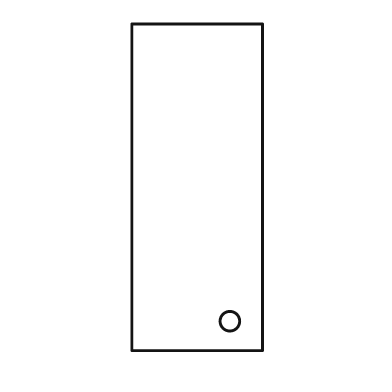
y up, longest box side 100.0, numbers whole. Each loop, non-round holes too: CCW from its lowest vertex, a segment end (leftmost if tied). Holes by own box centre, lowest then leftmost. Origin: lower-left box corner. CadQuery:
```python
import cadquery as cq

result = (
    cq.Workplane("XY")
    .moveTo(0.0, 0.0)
    .lineTo(40.0, 0.0)
    .lineTo(40.0, 100.0)
    .lineTo(0.0, 100.0)
    .close()
    .moveTo(30.0, 9.0)
    .circle(3.0)
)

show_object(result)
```